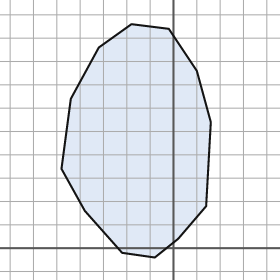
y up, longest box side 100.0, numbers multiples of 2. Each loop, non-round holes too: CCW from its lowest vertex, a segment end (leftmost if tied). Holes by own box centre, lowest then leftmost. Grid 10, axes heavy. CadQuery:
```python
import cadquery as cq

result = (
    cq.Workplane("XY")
    .moveTo(-8.0, -4.0)
    .lineTo(2.0, 4.0)
    .lineTo(14.0, 18.0)
    .lineTo(16.0, 54.0)
    .lineTo(10.0, 76.0)
    .lineTo(-2.0, 94.0)
    .lineTo(-18.0, 96.0)
    .lineTo(-32.0, 86.0)
    .lineTo(-44.0, 64.0)
    .lineTo(-48.0, 34.0)
    .lineTo(-38.0, 16.0)
    .lineTo(-22.0, -2.0)
    .close()
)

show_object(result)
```